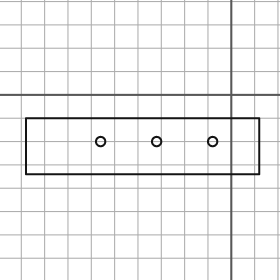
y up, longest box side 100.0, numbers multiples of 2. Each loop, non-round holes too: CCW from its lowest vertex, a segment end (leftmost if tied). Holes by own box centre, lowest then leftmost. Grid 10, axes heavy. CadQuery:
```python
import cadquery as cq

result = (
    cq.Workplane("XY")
    .moveTo(-88.0, -34.0)
    .lineTo(12.0, -34.0)
    .lineTo(12.0, -10.0)
    .lineTo(-88.0, -10.0)
    .close()
    .moveTo(-56.0, -20.0)
    .circle(2.0)
    .moveTo(-32.0, -20.0)
    .circle(2.0)
    .moveTo(-8.0, -20.0)
    .circle(2.0)
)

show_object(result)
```